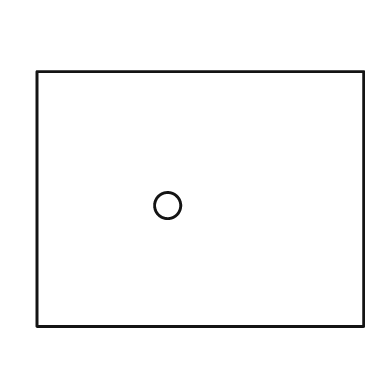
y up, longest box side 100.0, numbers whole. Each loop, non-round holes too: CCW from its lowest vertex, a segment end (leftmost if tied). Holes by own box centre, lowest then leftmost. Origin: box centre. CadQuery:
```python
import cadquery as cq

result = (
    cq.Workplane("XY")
    .moveTo(-50.0, -39.0)
    .lineTo(50.0, -39.0)
    .lineTo(50.0, 39.0)
    .lineTo(-50.0, 39.0)
    .close()
    .moveTo(-10.0, -2.0)
    .circle(4.0)
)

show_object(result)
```